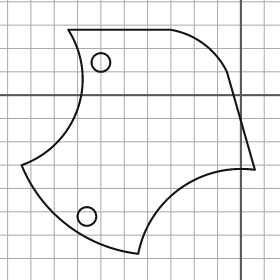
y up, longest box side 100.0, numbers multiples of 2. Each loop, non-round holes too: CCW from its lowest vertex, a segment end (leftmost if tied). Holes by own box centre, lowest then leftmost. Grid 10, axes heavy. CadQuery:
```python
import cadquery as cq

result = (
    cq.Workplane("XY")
    .moveTo(-44.0, -68.0)
    .threePointArc((-26.0, -40.0), (6.0, -32.0))
    .lineTo(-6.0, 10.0)
    .threePointArc((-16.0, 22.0), (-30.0, 28.0))
    .lineTo(-74.0, 28.0)
    .threePointArc((-70.0, -6.0), (-94.0, -30.0))
    .threePointArc((-74.0, -56.0), (-44.0, -68.0))
    .close()
    .moveTo(-66.0, -52.0)
    .circle(4.0)
    .moveTo(-60.0, 14.0)
    .circle(4.0)
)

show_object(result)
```